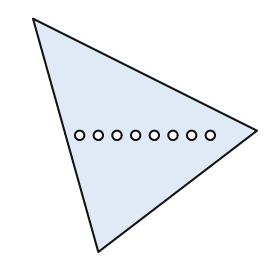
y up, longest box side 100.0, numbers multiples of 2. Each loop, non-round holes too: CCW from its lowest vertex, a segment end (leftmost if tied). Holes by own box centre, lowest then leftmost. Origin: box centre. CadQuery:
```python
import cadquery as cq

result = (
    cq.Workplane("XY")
    .moveTo(-20.0, -50.0)
    .lineTo(48.0, 2.0)
    .lineTo(-48.0, 50.0)
    .close()
    .moveTo(-28.0, 0.0)
    .circle(2.0)
    .moveTo(-20.0, 0.0)
    .circle(2.0)
    .moveTo(-12.0, 0.0)
    .circle(2.0)
    .moveTo(-4.0, 0.0)
    .circle(2.0)
    .moveTo(4.0, 0.0)
    .circle(2.0)
    .moveTo(12.0, 0.0)
    .circle(2.0)
    .moveTo(20.0, 0.0)
    .circle(2.0)
    .moveTo(28.0, 0.0)
    .circle(2.0)
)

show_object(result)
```